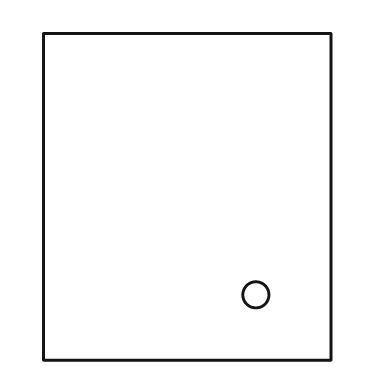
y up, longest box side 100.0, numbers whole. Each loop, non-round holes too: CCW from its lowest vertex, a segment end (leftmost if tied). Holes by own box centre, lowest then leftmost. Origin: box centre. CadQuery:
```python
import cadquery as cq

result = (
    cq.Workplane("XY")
    .moveTo(-44.0, -50.0)
    .lineTo(44.0, -50.0)
    .lineTo(44.0, 50.0)
    .lineTo(-44.0, 50.0)
    .close()
    .moveTo(21.0, -30.0)
    .circle(4.0)
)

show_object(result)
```